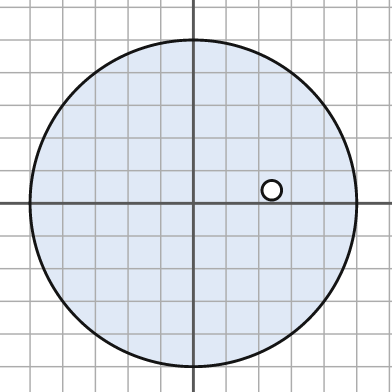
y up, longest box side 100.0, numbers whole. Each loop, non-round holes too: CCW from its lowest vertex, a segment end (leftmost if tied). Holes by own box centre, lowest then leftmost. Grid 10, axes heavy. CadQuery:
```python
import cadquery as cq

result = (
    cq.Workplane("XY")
    .moveTo(0.0, 0.0)
    .circle(50.0)
    .moveTo(24.0, 4.0)
    .circle(3.0)
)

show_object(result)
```